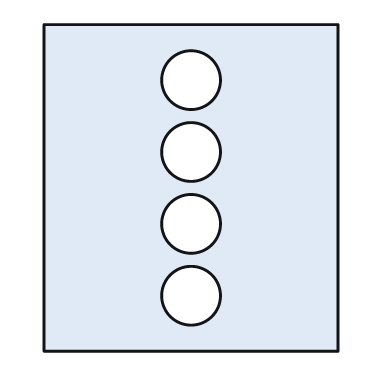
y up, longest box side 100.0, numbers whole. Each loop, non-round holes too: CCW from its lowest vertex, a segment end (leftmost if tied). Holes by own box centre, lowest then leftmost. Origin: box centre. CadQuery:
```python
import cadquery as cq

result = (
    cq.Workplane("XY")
    .moveTo(-45.0, -50.0)
    .lineTo(45.0, -50.0)
    .lineTo(45.0, 50.0)
    .lineTo(-45.0, 50.0)
    .close()
    .moveTo(0.0, -33.0)
    .circle(9.0)
    .moveTo(0.0, -11.0)
    .circle(9.0)
    .moveTo(0.0, 11.0)
    .circle(9.0)
    .moveTo(0.0, 33.0)
    .circle(9.0)
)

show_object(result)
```